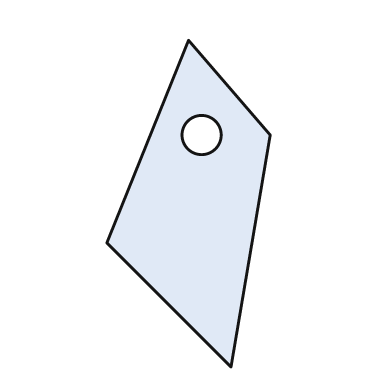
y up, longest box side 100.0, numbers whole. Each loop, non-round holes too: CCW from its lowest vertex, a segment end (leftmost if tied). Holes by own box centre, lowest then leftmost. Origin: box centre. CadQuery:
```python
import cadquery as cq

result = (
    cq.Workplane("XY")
    .moveTo(13.0, -50.0)
    .lineTo(25.0, 21.0)
    .lineTo(0.0, 50.0)
    .lineTo(-25.0, -12.0)
    .close()
    .moveTo(4.0, 21.0)
    .circle(6.0)
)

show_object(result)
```